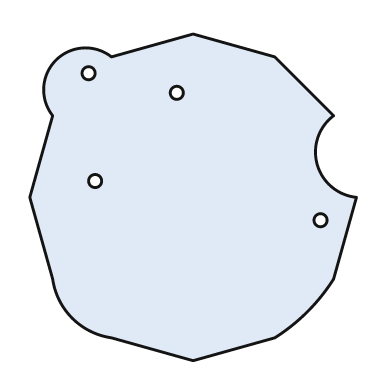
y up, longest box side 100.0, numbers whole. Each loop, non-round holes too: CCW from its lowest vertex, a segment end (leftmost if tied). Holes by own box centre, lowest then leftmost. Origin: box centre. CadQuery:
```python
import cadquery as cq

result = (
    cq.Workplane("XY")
    .moveTo(0.0, -50.0)
    .lineTo(25.0, -43.0)
    .threePointArc((35.0, -35.0), (43.0, -25.0))
    .lineTo(50.0, 0.0)
    .threePointArc((38.0, 10.0), (43.0, 25.0))
    .lineTo(25.0, 43.0)
    .lineTo(0.0, 50.0)
    .lineTo(-25.0, 43.0)
    .threePointArc((-42.0, 42.0), (-43.0, 25.0))
    .lineTo(-50.0, 0.0)
    .lineTo(-43.0, -25.0)
    .threePointArc((-37.0, -37.0), (-25.0, -43.0))
    .close()
    .moveTo(39.0, -7.0)
    .circle(2.0)
    .moveTo(-30.0, 5.0)
    .circle(2.0)
    .moveTo(-5.0, 32.0)
    .circle(2.0)
    .moveTo(-32.0, 38.0)
    .circle(2.0)
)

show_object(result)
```